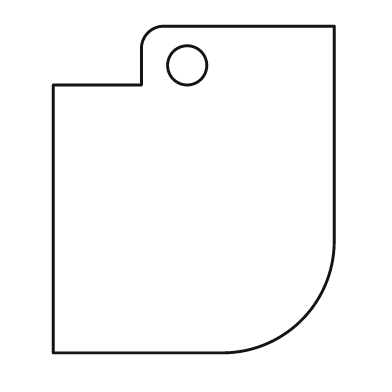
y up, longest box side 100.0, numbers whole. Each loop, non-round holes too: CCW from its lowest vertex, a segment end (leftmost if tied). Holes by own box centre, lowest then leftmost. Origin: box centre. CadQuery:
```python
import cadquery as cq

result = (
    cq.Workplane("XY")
    .moveTo(-43.0, -50.0)
    .lineTo(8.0, -50.0)
    .threePointArc((33.0, -40.0), (43.0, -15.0))
    .lineTo(43.0, 50.0)
    .lineTo(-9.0, 50.0)
    .threePointArc((-14.0, 48.0), (-16.0, 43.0))
    .lineTo(-16.0, 32.0)
    .lineTo(-43.0, 32.0)
    .close()
    .moveTo(-2.0, 38.0)
    .circle(6.0)
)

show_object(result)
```